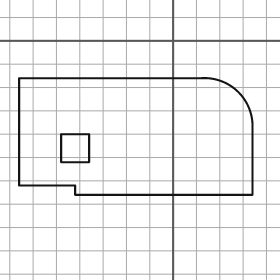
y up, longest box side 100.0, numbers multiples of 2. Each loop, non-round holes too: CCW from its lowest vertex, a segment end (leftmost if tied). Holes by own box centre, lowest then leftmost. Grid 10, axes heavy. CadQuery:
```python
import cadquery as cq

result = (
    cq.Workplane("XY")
    .moveTo(-42.0, -66.0)
    .lineTo(34.0, -66.0)
    .lineTo(34.0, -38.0)
    .threePointArc((28.0, -22.0), (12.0, -16.0))
    .lineTo(-66.0, -16.0)
    .lineTo(-66.0, -62.0)
    .lineTo(-42.0, -62.0)
    .close()
    .moveTo(-48.0, -52.0)
    .lineTo(-36.0, -52.0)
    .lineTo(-36.0, -40.0)
    .lineTo(-48.0, -40.0)
    .close()
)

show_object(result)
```